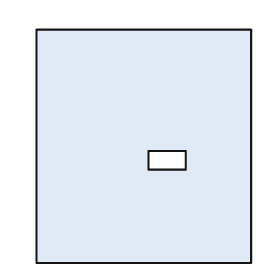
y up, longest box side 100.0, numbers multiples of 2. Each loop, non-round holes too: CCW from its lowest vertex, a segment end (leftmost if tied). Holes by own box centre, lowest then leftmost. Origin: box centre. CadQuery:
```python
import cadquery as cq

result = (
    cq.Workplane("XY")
    .moveTo(-46.0, -50.0)
    .lineTo(46.0, -50.0)
    .lineTo(46.0, 50.0)
    .lineTo(-46.0, 50.0)
    .close()
    .moveTo(2.0, -10.0)
    .lineTo(18.0, -10.0)
    .lineTo(18.0, -2.0)
    .lineTo(2.0, -2.0)
    .close()
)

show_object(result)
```